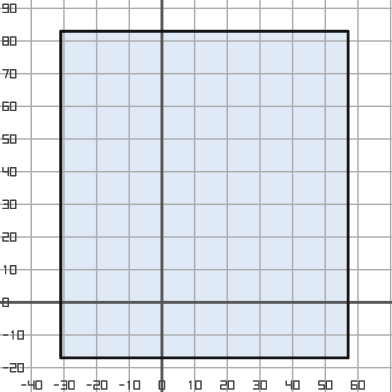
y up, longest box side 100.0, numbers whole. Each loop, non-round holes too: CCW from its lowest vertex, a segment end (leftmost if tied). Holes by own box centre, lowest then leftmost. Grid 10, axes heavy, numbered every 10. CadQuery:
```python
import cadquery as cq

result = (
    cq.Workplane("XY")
    .moveTo(-31.0, -17.0)
    .lineTo(57.0, -17.0)
    .lineTo(57.0, 83.0)
    .lineTo(-31.0, 83.0)
    .close()
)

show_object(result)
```